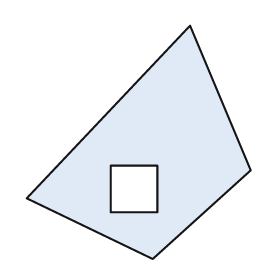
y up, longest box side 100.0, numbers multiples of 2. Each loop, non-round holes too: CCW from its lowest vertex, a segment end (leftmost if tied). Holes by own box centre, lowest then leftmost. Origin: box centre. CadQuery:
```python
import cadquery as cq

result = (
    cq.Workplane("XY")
    .moveTo(6.0, -50.0)
    .lineTo(48.0, -12.0)
    .lineTo(22.0, 50.0)
    .lineTo(-48.0, -24.0)
    .close()
    .moveTo(-12.0, -30.0)
    .lineTo(8.0, -30.0)
    .lineTo(8.0, -10.0)
    .lineTo(-12.0, -10.0)
    .close()
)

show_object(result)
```